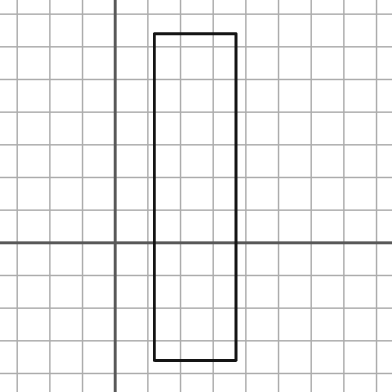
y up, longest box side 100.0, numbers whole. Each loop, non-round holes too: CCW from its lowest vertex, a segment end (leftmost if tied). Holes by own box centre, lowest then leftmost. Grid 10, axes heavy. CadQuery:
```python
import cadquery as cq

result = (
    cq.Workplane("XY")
    .moveTo(12.0, -36.0)
    .lineTo(37.0, -36.0)
    .lineTo(37.0, 64.0)
    .lineTo(12.0, 64.0)
    .close()
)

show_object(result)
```